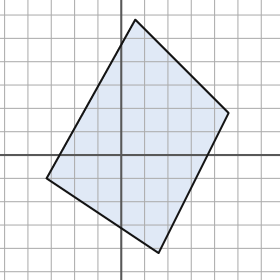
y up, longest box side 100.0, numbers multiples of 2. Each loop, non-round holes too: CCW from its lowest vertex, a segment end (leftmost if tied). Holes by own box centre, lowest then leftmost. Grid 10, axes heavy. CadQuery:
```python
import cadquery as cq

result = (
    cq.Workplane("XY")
    .moveTo(16.0, -42.0)
    .lineTo(46.0, 18.0)
    .lineTo(6.0, 58.0)
    .lineTo(-32.0, -10.0)
    .close()
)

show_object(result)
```